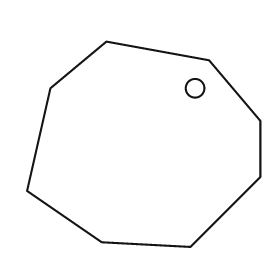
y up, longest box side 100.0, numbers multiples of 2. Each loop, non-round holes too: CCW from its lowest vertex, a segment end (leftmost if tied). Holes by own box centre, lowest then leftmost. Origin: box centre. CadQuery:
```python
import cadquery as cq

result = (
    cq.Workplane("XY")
    .moveTo(20.0, -44.0)
    .lineTo(50.0, -14.0)
    .lineTo(50.0, 10.0)
    .lineTo(28.0, 36.0)
    .lineTo(-16.0, 44.0)
    .lineTo(-40.0, 24.0)
    .lineTo(-50.0, -20.0)
    .lineTo(-18.0, -42.0)
    .close()
    .moveTo(22.0, 24.0)
    .circle(4.0)
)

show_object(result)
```